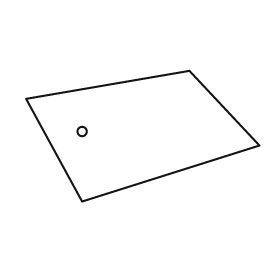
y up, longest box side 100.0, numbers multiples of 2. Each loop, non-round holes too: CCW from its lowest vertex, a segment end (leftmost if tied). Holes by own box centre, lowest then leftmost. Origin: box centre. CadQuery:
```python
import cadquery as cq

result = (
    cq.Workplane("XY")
    .moveTo(-26.0, -28.0)
    .lineTo(50.0, -4.0)
    .lineTo(20.0, 28.0)
    .lineTo(-50.0, 16.0)
    .close()
    .moveTo(-26.0, 2.0)
    .circle(2.0)
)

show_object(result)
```